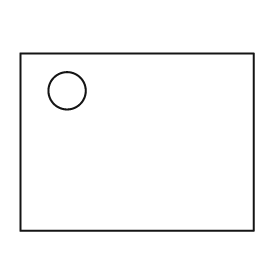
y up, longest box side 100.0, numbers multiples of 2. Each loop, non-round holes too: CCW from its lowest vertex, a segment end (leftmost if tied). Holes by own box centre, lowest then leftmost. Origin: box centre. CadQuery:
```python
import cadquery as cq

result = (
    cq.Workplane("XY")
    .moveTo(-50.0, -38.0)
    .lineTo(50.0, -38.0)
    .lineTo(50.0, 38.0)
    .lineTo(-50.0, 38.0)
    .close()
    .moveTo(-30.0, 22.0)
    .circle(8.0)
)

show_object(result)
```